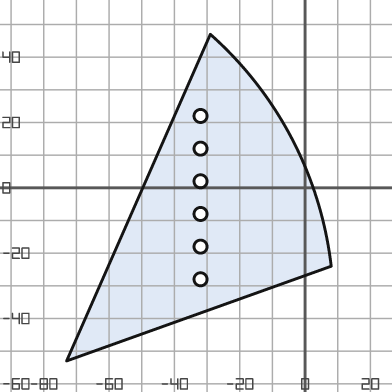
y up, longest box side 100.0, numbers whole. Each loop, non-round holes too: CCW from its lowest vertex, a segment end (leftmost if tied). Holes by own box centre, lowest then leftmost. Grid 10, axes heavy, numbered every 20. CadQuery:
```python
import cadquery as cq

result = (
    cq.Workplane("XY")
    .moveTo(-73.0, -53.0)
    .lineTo(8.0, -24.0)
    .threePointArc((-4.0, 15.0), (-29.0, 47.0))
    .close()
    .moveTo(-32.0, -28.0)
    .circle(2.0)
    .moveTo(-32.0, -18.0)
    .circle(2.0)
    .moveTo(-32.0, -8.0)
    .circle(2.0)
    .moveTo(-32.0, 2.0)
    .circle(2.0)
    .moveTo(-32.0, 12.0)
    .circle(2.0)
    .moveTo(-32.0, 22.0)
    .circle(2.0)
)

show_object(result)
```